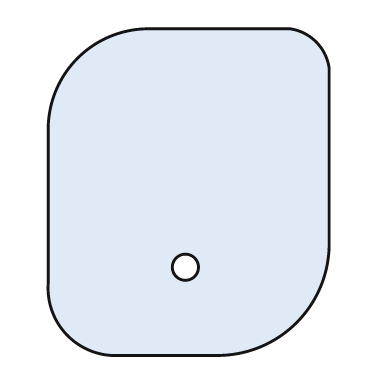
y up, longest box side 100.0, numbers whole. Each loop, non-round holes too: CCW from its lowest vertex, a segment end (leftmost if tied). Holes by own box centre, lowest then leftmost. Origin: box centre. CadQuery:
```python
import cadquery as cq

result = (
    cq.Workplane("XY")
    .moveTo(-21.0, -50.0)
    .lineTo(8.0, -50.0)
    .threePointArc((33.0, -40.0), (43.0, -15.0))
    .lineTo(43.0, 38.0)
    .threePointArc((39.0, 46.0), (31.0, 50.0))
    .lineTo(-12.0, 50.0)
    .threePointArc((-34.0, 41.0), (-43.0, 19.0))
    .lineTo(-43.0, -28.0)
    .threePointArc((-37.0, -44.0), (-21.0, -50.0))
    .close()
    .moveTo(-1.0, -23.0)
    .circle(4.0)
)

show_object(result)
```